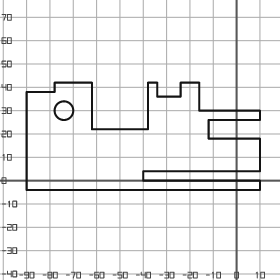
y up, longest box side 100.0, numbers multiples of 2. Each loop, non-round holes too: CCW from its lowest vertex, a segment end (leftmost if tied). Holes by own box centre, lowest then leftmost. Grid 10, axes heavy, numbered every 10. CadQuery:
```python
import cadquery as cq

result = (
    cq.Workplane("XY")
    .moveTo(-90.0, -4.0)
    .lineTo(10.0, -4.0)
    .lineTo(10.0, 0.0)
    .lineTo(-40.0, 0.0)
    .lineTo(-40.0, 4.0)
    .lineTo(10.0, 4.0)
    .lineTo(10.0, 18.0)
    .lineTo(-12.0, 18.0)
    .lineTo(-12.0, 26.0)
    .lineTo(10.0, 26.0)
    .lineTo(10.0, 30.0)
    .lineTo(-16.0, 30.0)
    .lineTo(-16.0, 42.0)
    .lineTo(-24.0, 42.0)
    .lineTo(-24.0, 36.0)
    .lineTo(-34.0, 36.0)
    .lineTo(-34.0, 42.0)
    .lineTo(-38.0, 42.0)
    .lineTo(-38.0, 22.0)
    .lineTo(-62.0, 22.0)
    .lineTo(-62.0, 42.0)
    .lineTo(-78.0, 42.0)
    .lineTo(-78.0, 38.0)
    .lineTo(-90.0, 38.0)
    .close()
    .moveTo(-74.0, 30.0)
    .circle(4.0)
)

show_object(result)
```